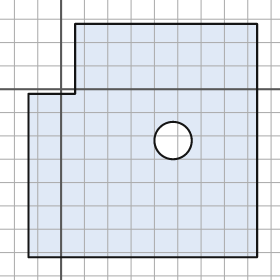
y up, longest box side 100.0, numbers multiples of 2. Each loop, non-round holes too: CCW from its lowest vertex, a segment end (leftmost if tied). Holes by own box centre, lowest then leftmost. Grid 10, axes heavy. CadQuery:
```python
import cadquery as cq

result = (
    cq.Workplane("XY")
    .moveTo(-14.0, -72.0)
    .lineTo(84.0, -72.0)
    .lineTo(84.0, 28.0)
    .lineTo(6.0, 28.0)
    .lineTo(6.0, -2.0)
    .lineTo(-14.0, -2.0)
    .close()
    .moveTo(48.0, -22.0)
    .circle(8.0)
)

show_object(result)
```